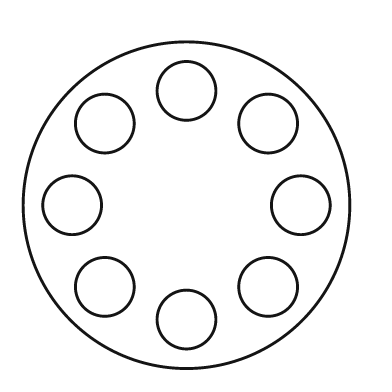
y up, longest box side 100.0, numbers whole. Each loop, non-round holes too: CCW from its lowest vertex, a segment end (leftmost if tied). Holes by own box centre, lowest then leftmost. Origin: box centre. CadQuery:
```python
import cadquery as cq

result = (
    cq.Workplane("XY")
    .moveTo(0.0, 0.0)
    .circle(50.0)
    .moveTo(0.0, -35.0)
    .circle(9.0)
    .moveTo(-25.0, -25.0)
    .circle(9.0)
    .moveTo(25.0, -25.0)
    .circle(9.0)
    .moveTo(-35.0, 0.0)
    .circle(9.0)
    .moveTo(35.0, 0.0)
    .circle(9.0)
    .moveTo(-25.0, 25.0)
    .circle(9.0)
    .moveTo(25.0, 25.0)
    .circle(9.0)
    .moveTo(0.0, 35.0)
    .circle(9.0)
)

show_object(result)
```